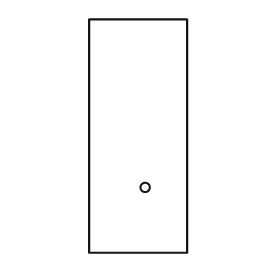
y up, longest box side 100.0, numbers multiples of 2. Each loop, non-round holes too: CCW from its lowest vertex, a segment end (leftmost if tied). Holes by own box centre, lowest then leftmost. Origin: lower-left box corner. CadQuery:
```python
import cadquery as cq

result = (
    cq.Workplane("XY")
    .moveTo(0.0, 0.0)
    .lineTo(42.0, 0.0)
    .lineTo(42.0, 100.0)
    .lineTo(0.0, 100.0)
    .close()
    .moveTo(24.0, 28.0)
    .circle(2.0)
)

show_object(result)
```